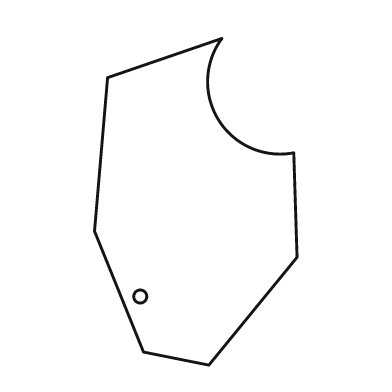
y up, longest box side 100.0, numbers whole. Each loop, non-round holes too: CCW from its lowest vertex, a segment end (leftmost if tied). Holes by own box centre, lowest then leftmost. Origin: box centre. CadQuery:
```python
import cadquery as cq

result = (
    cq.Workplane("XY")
    .moveTo(4.0, -50.0)
    .lineTo(31.0, -17.0)
    .lineTo(30.0, 15.0)
    .threePointArc((7.0, 25.0), (8.0, 50.0))
    .lineTo(-27.0, 38.0)
    .lineTo(-31.0, -9.0)
    .lineTo(-16.0, -46.0)
    .close()
    .moveTo(-17.0, -29.0)
    .circle(2.0)
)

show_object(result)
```